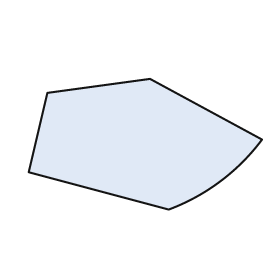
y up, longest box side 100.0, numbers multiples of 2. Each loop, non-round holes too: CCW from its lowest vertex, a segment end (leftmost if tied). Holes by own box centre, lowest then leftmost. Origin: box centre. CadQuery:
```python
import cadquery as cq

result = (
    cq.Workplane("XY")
    .moveTo(10.0, -28.0)
    .threePointArc((32.0, -16.0), (50.0, 2.0))
    .lineTo(2.0, 28.0)
    .lineTo(-42.0, 22.0)
    .lineTo(-50.0, -12.0)
    .close()
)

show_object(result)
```